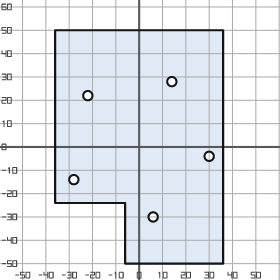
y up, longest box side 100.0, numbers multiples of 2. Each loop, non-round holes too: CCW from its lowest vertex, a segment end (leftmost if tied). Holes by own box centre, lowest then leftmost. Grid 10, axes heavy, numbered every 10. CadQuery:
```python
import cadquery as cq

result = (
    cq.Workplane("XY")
    .moveTo(-6.0, -50.0)
    .lineTo(36.0, -50.0)
    .lineTo(36.0, 50.0)
    .lineTo(-36.0, 50.0)
    .lineTo(-36.0, -24.0)
    .lineTo(-6.0, -24.0)
    .close()
    .moveTo(6.0, -30.0)
    .circle(2.0)
    .moveTo(-28.0, -14.0)
    .circle(2.0)
    .moveTo(30.0, -4.0)
    .circle(2.0)
    .moveTo(-22.0, 22.0)
    .circle(2.0)
    .moveTo(14.0, 28.0)
    .circle(2.0)
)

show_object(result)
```